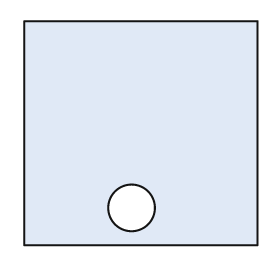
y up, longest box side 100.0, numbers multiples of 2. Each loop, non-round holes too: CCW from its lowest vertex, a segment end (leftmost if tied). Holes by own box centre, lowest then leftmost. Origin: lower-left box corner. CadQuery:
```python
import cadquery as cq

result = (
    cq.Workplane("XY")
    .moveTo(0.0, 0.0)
    .lineTo(100.0, 0.0)
    .lineTo(100.0, 96.0)
    .lineTo(0.0, 96.0)
    .close()
    .moveTo(46.0, 16.0)
    .circle(10.0)
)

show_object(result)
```